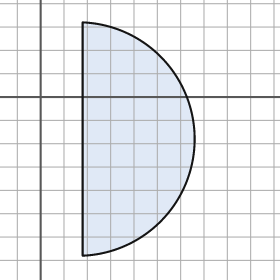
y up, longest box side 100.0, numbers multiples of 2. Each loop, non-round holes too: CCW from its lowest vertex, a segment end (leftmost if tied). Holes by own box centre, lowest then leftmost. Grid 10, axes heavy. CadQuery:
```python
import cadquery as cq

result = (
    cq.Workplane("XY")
    .moveTo(18.0, -68.0)
    .threePointArc((66.0, -18.0), (18.0, 32.0))
    .close()
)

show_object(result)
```